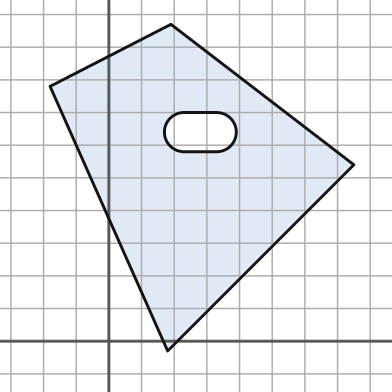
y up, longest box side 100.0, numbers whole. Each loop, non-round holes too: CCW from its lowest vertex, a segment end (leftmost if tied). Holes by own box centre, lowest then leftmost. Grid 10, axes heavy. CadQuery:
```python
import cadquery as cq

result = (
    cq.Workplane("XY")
    .moveTo(18.0, -3.0)
    .lineTo(75.0, 54.0)
    .lineTo(19.0, 97.0)
    .lineTo(-18.0, 78.0)
    .close()
    .moveTo(23.0, 58.0)
    .lineTo(33.0, 58.0)
    .threePointArc((39.0, 64.0), (33.0, 70.0))
    .lineTo(23.0, 70.0)
    .threePointArc((17.0, 64.0), (23.0, 58.0))
    .close()
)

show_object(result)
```